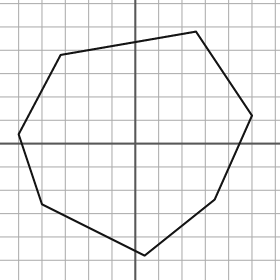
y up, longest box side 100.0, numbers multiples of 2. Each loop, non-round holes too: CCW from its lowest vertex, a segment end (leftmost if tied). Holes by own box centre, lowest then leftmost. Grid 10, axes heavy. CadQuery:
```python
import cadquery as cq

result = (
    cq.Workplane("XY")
    .moveTo(4.0, -48.0)
    .lineTo(34.0, -24.0)
    .lineTo(50.0, 12.0)
    .lineTo(26.0, 48.0)
    .lineTo(-32.0, 38.0)
    .lineTo(-50.0, 4.0)
    .lineTo(-40.0, -26.0)
    .close()
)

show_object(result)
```